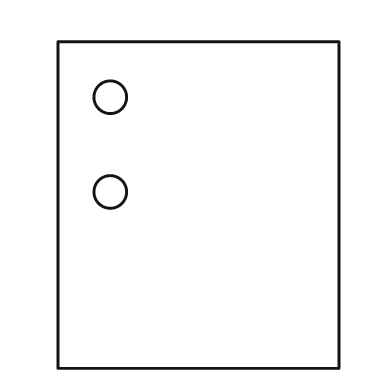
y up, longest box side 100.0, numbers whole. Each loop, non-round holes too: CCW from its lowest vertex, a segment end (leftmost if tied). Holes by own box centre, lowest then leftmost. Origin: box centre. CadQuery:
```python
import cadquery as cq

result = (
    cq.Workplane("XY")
    .moveTo(-43.0, -50.0)
    .lineTo(43.0, -50.0)
    .lineTo(43.0, 50.0)
    .lineTo(-43.0, 50.0)
    .close()
    .moveTo(-27.0, 4.0)
    .circle(5.0)
    .moveTo(-27.0, 33.0)
    .circle(5.0)
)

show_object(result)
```